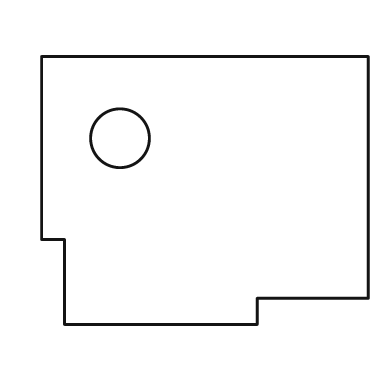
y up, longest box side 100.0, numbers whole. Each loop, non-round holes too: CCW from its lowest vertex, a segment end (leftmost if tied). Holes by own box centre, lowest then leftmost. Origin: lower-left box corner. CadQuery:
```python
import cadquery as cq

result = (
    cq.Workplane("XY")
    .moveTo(7.0, 0.0)
    .lineTo(66.0, 0.0)
    .lineTo(66.0, 8.0)
    .lineTo(100.0, 8.0)
    .lineTo(100.0, 82.0)
    .lineTo(0.0, 82.0)
    .lineTo(0.0, 26.0)
    .lineTo(7.0, 26.0)
    .close()
    .moveTo(24.0, 57.0)
    .circle(9.0)
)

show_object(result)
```